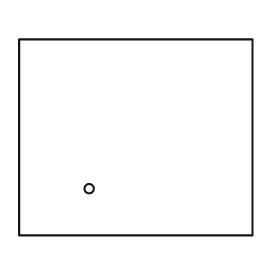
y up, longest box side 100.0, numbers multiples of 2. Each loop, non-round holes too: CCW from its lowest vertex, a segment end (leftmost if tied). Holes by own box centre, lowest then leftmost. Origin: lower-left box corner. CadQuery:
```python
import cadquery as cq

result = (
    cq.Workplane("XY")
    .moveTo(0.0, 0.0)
    .lineTo(100.0, 0.0)
    .lineTo(100.0, 84.0)
    .lineTo(0.0, 84.0)
    .close()
    .moveTo(30.0, 20.0)
    .circle(2.0)
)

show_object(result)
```